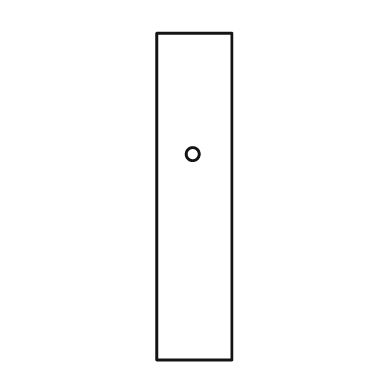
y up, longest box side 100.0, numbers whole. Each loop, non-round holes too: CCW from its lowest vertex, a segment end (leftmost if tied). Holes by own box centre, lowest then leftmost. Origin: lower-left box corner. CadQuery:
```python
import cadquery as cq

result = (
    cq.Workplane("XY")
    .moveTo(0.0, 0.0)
    .lineTo(23.0, 0.0)
    .lineTo(23.0, 100.0)
    .lineTo(0.0, 100.0)
    .close()
    .moveTo(11.0, 63.0)
    .circle(2.0)
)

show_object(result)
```